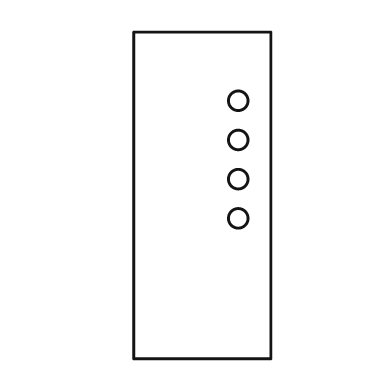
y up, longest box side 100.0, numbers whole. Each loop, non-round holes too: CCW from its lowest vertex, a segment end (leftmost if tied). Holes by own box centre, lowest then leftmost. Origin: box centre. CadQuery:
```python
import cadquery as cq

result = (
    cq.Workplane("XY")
    .moveTo(-21.0, -50.0)
    .lineTo(21.0, -50.0)
    .lineTo(21.0, 50.0)
    .lineTo(-21.0, 50.0)
    .close()
    .moveTo(11.0, -7.0)
    .circle(3.0)
    .moveTo(11.0, 5.0)
    .circle(3.0)
    .moveTo(11.0, 17.0)
    .circle(3.0)
    .moveTo(11.0, 29.0)
    .circle(3.0)
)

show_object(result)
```